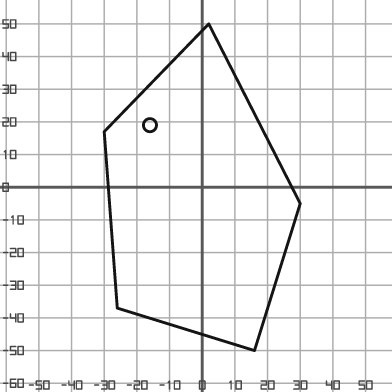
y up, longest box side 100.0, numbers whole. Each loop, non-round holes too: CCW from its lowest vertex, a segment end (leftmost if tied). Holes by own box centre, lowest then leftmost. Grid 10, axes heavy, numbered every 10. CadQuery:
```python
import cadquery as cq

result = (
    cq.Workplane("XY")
    .moveTo(16.0, -50.0)
    .lineTo(30.0, -5.0)
    .lineTo(2.0, 50.0)
    .lineTo(-30.0, 17.0)
    .lineTo(-26.0, -37.0)
    .close()
    .moveTo(-16.0, 19.0)
    .circle(2.0)
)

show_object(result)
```